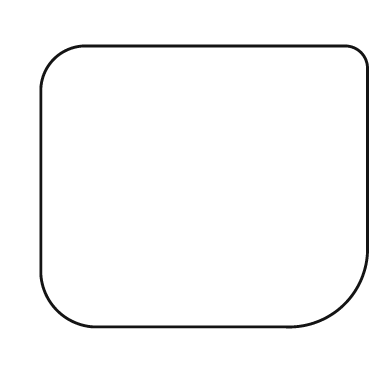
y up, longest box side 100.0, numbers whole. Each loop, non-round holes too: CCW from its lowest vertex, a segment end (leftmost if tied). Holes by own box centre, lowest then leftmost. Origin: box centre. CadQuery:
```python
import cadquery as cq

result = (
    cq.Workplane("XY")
    .moveTo(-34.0, -43.0)
    .lineTo(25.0, -43.0)
    .threePointArc((43.0, -36.0), (50.0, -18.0))
    .lineTo(50.0, 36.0)
    .threePointArc((48.0, 41.0), (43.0, 43.0))
    .lineTo(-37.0, 43.0)
    .threePointArc((-46.0, 39.0), (-50.0, 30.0))
    .lineTo(-50.0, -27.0)
    .threePointArc((-45.0, -38.0), (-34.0, -43.0))
    .close()
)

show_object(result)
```